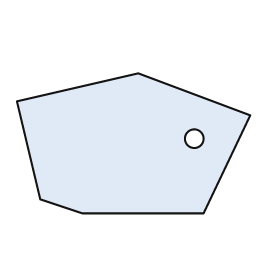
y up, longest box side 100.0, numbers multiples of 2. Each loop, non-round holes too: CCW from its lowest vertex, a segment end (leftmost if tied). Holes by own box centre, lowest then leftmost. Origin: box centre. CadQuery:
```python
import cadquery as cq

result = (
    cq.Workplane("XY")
    .moveTo(-22.0, -30.0)
    .lineTo(30.0, -30.0)
    .lineTo(50.0, 12.0)
    .lineTo(2.0, 30.0)
    .lineTo(-50.0, 18.0)
    .lineTo(-40.0, -24.0)
    .close()
    .moveTo(26.0, 2.0)
    .circle(4.0)
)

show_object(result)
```